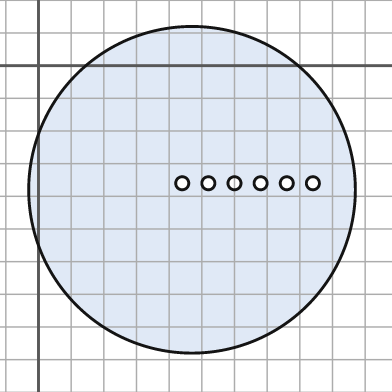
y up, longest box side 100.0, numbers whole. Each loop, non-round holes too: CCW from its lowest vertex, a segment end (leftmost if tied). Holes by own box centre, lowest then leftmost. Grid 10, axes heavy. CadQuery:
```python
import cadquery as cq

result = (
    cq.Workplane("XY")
    .moveTo(47.0, -38.0)
    .circle(50.0)
    .moveTo(44.0, -36.0)
    .circle(2.0)
    .moveTo(52.0, -36.0)
    .circle(2.0)
    .moveTo(60.0, -36.0)
    .circle(2.0)
    .moveTo(68.0, -36.0)
    .circle(2.0)
    .moveTo(76.0, -36.0)
    .circle(2.0)
    .moveTo(84.0, -36.0)
    .circle(2.0)
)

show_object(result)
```